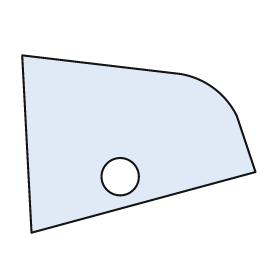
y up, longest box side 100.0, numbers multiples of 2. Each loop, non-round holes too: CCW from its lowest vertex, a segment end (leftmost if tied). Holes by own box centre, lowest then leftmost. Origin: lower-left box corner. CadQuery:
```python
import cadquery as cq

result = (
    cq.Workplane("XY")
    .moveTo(4.0, 0.0)
    .lineTo(100.0, 26.0)
    .lineTo(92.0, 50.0)
    .threePointArc((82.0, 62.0), (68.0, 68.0))
    .lineTo(0.0, 76.0)
    .close()
    .moveTo(42.0, 24.0)
    .circle(8.0)
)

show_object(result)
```